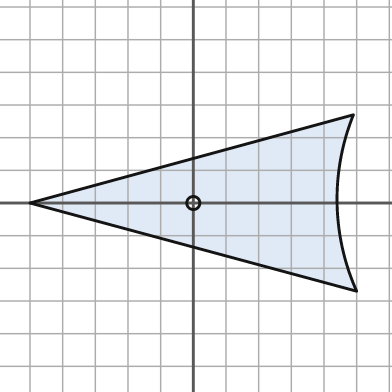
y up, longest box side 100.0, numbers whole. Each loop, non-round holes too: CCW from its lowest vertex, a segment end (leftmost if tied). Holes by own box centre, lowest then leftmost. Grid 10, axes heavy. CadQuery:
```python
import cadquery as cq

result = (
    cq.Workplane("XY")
    .moveTo(50.0, -27.0)
    .threePointArc((44.0, 0.0), (49.0, 27.0))
    .lineTo(-50.0, 0.0)
    .close()
    .moveTo(0.0, 0.0)
    .circle(2.0)
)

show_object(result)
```